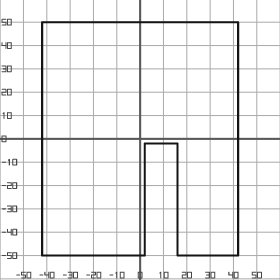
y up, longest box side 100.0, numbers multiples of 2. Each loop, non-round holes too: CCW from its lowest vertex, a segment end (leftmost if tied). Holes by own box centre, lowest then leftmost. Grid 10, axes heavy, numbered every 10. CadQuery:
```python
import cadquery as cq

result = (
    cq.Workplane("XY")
    .moveTo(-42.0, -50.0)
    .lineTo(2.0, -50.0)
    .lineTo(2.0, -2.0)
    .lineTo(16.0, -2.0)
    .lineTo(16.0, -50.0)
    .lineTo(42.0, -50.0)
    .lineTo(42.0, 50.0)
    .lineTo(-42.0, 50.0)
    .close()
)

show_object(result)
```